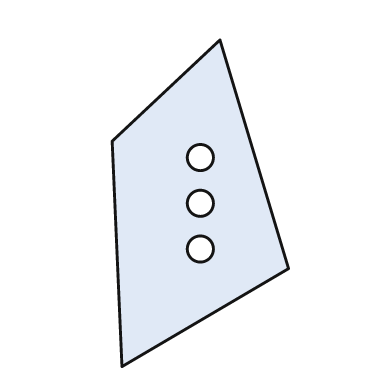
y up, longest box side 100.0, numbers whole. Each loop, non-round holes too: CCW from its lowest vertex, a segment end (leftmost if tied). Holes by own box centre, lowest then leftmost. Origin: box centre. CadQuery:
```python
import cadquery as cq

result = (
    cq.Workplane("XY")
    .moveTo(-24.0, -50.0)
    .lineTo(27.0, -20.0)
    .lineTo(6.0, 50.0)
    .lineTo(-27.0, 19.0)
    .close()
    .moveTo(0.0, -14.0)
    .circle(4.0)
    .moveTo(0.0, 0.0)
    .circle(4.0)
    .moveTo(0.0, 14.0)
    .circle(4.0)
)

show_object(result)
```